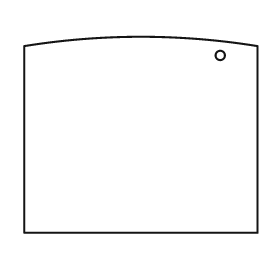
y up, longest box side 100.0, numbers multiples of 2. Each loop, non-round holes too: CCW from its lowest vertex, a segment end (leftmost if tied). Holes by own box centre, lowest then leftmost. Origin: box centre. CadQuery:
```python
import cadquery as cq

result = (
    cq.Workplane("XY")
    .moveTo(-50.0, -42.0)
    .lineTo(50.0, -42.0)
    .lineTo(50.0, 38.0)
    .threePointArc((0.0, 42.0), (-50.0, 38.0))
    .close()
    .moveTo(34.0, 34.0)
    .circle(2.0)
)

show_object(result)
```